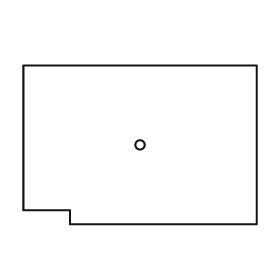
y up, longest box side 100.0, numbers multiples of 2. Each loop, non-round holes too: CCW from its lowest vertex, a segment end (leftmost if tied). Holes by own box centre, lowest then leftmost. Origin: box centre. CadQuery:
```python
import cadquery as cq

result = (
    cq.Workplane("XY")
    .moveTo(-30.0, -34.0)
    .lineTo(50.0, -34.0)
    .lineTo(50.0, 34.0)
    .lineTo(-50.0, 34.0)
    .lineTo(-50.0, -28.0)
    .lineTo(-30.0, -28.0)
    .close()
    .moveTo(0.0, 0.0)
    .circle(2.0)
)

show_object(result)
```